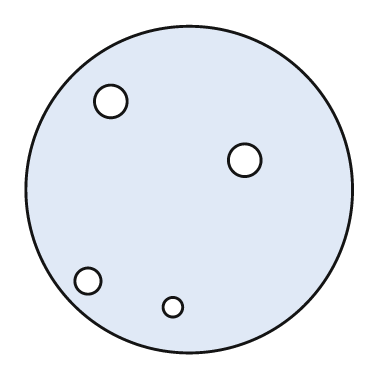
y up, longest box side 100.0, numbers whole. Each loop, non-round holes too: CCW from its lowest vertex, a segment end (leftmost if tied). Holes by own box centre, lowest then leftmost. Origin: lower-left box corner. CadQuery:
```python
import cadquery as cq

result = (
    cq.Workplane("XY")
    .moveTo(50.0, 50.0)
    .circle(50.0)
    .moveTo(45.0, 14.0)
    .circle(3.0)
    .moveTo(19.0, 22.0)
    .circle(4.0)
    .moveTo(67.0, 59.0)
    .circle(5.0)
    .moveTo(26.0, 77.0)
    .circle(5.0)
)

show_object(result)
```